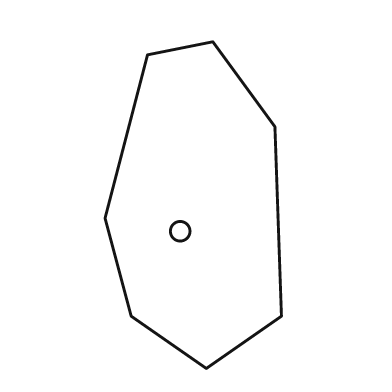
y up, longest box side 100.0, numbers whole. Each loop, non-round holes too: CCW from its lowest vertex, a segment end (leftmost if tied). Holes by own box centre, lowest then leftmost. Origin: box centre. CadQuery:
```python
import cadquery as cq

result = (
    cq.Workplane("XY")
    .moveTo(4.0, -50.0)
    .lineTo(27.0, -34.0)
    .lineTo(25.0, 24.0)
    .lineTo(6.0, 50.0)
    .lineTo(-14.0, 46.0)
    .lineTo(-27.0, -4.0)
    .lineTo(-19.0, -34.0)
    .close()
    .moveTo(-4.0, -8.0)
    .circle(3.0)
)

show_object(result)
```